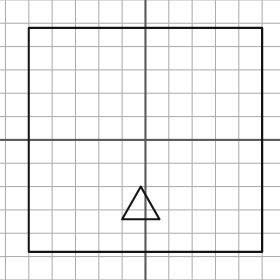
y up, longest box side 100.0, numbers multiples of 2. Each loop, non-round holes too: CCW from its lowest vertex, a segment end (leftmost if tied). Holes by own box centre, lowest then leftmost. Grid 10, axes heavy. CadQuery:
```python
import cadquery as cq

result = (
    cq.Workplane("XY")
    .moveTo(-50.0, -48.0)
    .lineTo(50.0, -48.0)
    .lineTo(50.0, 48.0)
    .lineTo(-50.0, 48.0)
    .close()
    .moveTo(-10.0, -34.0)
    .lineTo(6.0, -34.0)
    .lineTo(-2.0, -20.0)
    .close()
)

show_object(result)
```